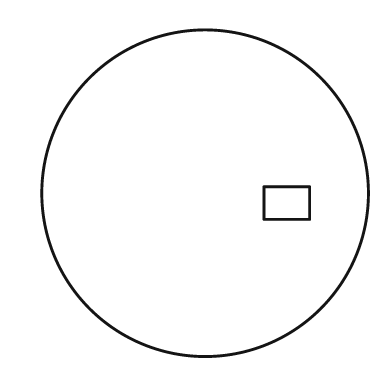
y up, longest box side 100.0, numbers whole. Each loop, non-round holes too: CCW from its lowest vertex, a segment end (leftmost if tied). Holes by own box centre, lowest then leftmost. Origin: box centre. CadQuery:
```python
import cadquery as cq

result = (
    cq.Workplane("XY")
    .moveTo(0.0, 0.0)
    .circle(50.0)
    .moveTo(18.0, -8.0)
    .lineTo(32.0, -8.0)
    .lineTo(32.0, 2.0)
    .lineTo(18.0, 2.0)
    .close()
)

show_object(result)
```